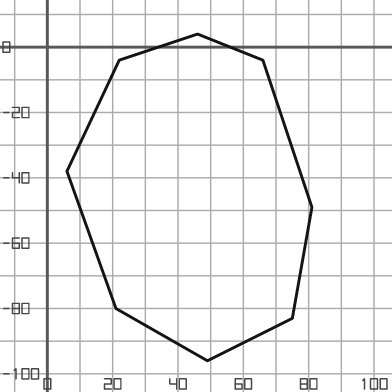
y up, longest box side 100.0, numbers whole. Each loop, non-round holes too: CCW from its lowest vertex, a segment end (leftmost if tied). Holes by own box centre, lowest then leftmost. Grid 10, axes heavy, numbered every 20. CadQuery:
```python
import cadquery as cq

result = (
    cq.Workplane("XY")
    .moveTo(49.0, -96.0)
    .lineTo(75.0, -83.0)
    .lineTo(81.0, -49.0)
    .lineTo(66.0, -4.0)
    .lineTo(46.0, 4.0)
    .lineTo(22.0, -4.0)
    .lineTo(6.0, -38.0)
    .lineTo(21.0, -80.0)
    .close()
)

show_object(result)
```